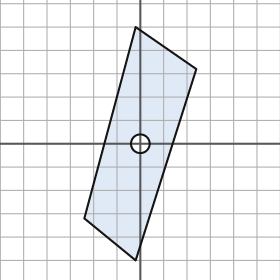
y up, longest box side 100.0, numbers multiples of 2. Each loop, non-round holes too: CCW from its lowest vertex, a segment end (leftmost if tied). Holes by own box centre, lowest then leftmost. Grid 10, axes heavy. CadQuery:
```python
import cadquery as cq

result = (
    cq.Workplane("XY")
    .moveTo(-2.0, -50.0)
    .lineTo(24.0, 32.0)
    .lineTo(-2.0, 50.0)
    .lineTo(-24.0, -32.0)
    .close()
    .moveTo(0.0, 0.0)
    .circle(4.0)
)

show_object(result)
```